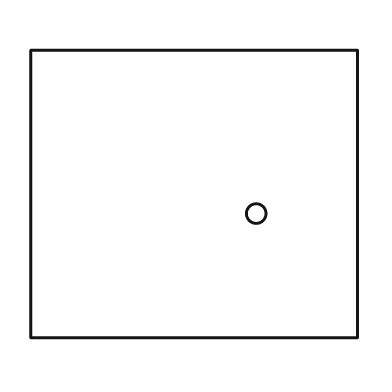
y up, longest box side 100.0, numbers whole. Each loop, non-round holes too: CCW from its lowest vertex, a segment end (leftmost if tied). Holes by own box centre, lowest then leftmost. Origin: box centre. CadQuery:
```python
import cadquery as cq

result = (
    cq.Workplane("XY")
    .moveTo(-50.0, -44.0)
    .lineTo(50.0, -44.0)
    .lineTo(50.0, 44.0)
    .lineTo(-50.0, 44.0)
    .close()
    .moveTo(19.0, -6.0)
    .circle(3.0)
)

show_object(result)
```